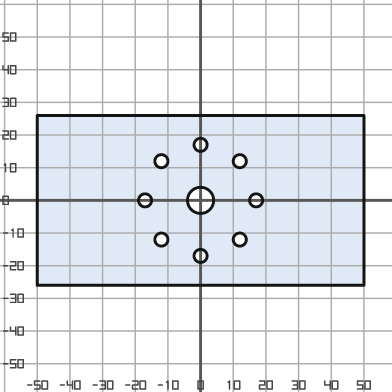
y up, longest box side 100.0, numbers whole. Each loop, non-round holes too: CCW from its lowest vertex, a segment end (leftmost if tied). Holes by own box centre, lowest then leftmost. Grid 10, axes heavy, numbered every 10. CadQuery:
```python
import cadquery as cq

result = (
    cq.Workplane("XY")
    .moveTo(-50.0, -26.0)
    .lineTo(50.0, -26.0)
    .lineTo(50.0, 26.0)
    .lineTo(-50.0, 26.0)
    .close()
    .moveTo(0.0, -17.0)
    .circle(2.0)
    .moveTo(-12.0, -12.0)
    .circle(2.0)
    .moveTo(12.0, -12.0)
    .circle(2.0)
    .moveTo(-17.0, 0.0)
    .circle(2.0)
    .moveTo(0.0, 0.0)
    .circle(4.0)
    .moveTo(17.0, 0.0)
    .circle(2.0)
    .moveTo(-12.0, 12.0)
    .circle(2.0)
    .moveTo(12.0, 12.0)
    .circle(2.0)
    .moveTo(0.0, 17.0)
    .circle(2.0)
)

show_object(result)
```